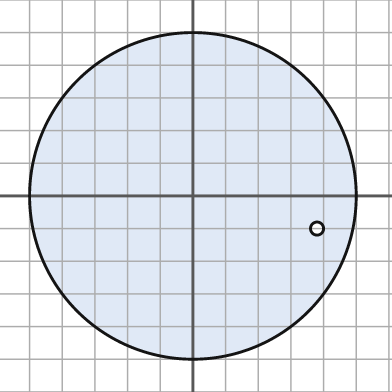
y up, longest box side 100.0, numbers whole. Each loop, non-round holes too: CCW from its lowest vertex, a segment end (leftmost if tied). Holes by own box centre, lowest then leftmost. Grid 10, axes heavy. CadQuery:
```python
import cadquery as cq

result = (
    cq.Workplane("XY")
    .moveTo(0.0, 0.0)
    .circle(50.0)
    .moveTo(38.0, -10.0)
    .circle(2.0)
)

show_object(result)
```